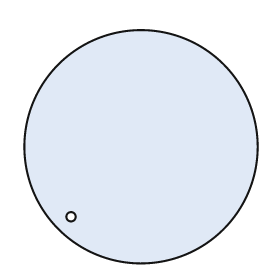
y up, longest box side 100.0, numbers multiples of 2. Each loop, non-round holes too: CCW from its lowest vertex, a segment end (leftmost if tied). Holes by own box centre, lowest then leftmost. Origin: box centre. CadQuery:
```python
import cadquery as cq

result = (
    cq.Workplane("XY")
    .moveTo(0.0, 0.0)
    .circle(50.0)
    .moveTo(-30.0, -30.0)
    .circle(2.0)
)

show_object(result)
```